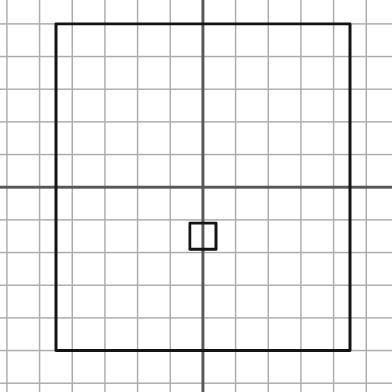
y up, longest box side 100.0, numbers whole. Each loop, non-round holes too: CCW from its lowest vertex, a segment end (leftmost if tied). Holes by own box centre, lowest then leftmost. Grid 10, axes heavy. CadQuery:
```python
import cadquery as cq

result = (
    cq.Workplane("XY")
    .moveTo(-45.0, -50.0)
    .lineTo(45.0, -50.0)
    .lineTo(45.0, 50.0)
    .lineTo(-45.0, 50.0)
    .close()
    .moveTo(-4.0, -19.0)
    .lineTo(4.0, -19.0)
    .lineTo(4.0, -11.0)
    .lineTo(-4.0, -11.0)
    .close()
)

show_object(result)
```